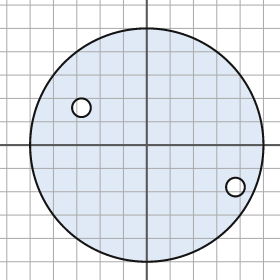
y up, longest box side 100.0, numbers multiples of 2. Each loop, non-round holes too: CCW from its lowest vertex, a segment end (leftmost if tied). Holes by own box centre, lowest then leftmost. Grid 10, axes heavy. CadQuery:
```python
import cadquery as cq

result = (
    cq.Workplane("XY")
    .moveTo(0.0, 0.0)
    .circle(50.0)
    .moveTo(38.0, -18.0)
    .circle(4.0)
    .moveTo(-28.0, 16.0)
    .circle(4.0)
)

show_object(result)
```